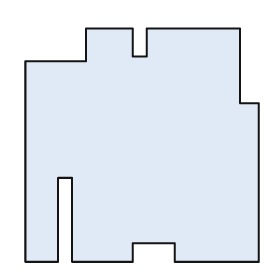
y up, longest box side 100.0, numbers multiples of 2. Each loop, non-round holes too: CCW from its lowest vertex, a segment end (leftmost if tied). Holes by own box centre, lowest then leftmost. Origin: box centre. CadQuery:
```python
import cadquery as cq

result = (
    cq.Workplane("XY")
    .moveTo(-50.0, -50.0)
    .lineTo(-36.0, -50.0)
    .lineTo(-36.0, -14.0)
    .lineTo(-30.0, -14.0)
    .lineTo(-30.0, -50.0)
    .lineTo(-4.0, -50.0)
    .lineTo(-4.0, -42.0)
    .lineTo(14.0, -42.0)
    .lineTo(14.0, -50.0)
    .lineTo(50.0, -50.0)
    .lineTo(50.0, 18.0)
    .lineTo(42.0, 18.0)
    .lineTo(42.0, 50.0)
    .lineTo(2.0, 50.0)
    .lineTo(2.0, 38.0)
    .lineTo(-4.0, 38.0)
    .lineTo(-4.0, 50.0)
    .lineTo(-24.0, 50.0)
    .lineTo(-24.0, 36.0)
    .lineTo(-50.0, 36.0)
    .close()
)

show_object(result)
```